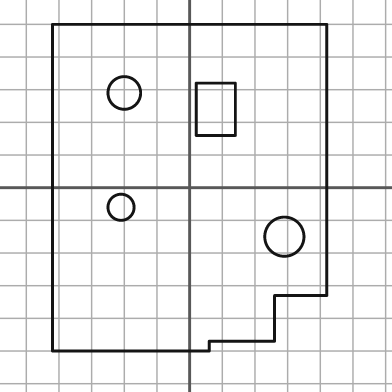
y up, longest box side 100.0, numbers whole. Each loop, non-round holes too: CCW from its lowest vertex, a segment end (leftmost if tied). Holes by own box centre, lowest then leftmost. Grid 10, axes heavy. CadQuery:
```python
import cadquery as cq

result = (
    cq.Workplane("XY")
    .moveTo(-42.0, -50.0)
    .lineTo(6.0, -50.0)
    .lineTo(6.0, -47.0)
    .lineTo(26.0, -47.0)
    .lineTo(26.0, -33.0)
    .lineTo(42.0, -33.0)
    .lineTo(42.0, 50.0)
    .lineTo(-42.0, 50.0)
    .close()
    .moveTo(29.0, -15.0)
    .circle(6.0)
    .moveTo(-21.0, -6.0)
    .circle(4.0)
    .moveTo(2.0, 16.0)
    .lineTo(14.0, 16.0)
    .lineTo(14.0, 32.0)
    .lineTo(2.0, 32.0)
    .close()
    .moveTo(-20.0, 29.0)
    .circle(5.0)
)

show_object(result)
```